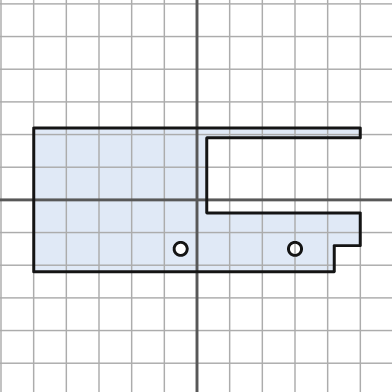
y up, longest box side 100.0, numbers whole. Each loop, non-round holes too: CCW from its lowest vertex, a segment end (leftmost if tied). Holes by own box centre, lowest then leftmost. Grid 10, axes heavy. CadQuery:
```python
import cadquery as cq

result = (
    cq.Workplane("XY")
    .moveTo(-50.0, -22.0)
    .lineTo(42.0, -22.0)
    .lineTo(42.0, -14.0)
    .lineTo(50.0, -14.0)
    .lineTo(50.0, -4.0)
    .lineTo(3.0, -4.0)
    .lineTo(3.0, 19.0)
    .lineTo(50.0, 19.0)
    .lineTo(50.0, 22.0)
    .lineTo(-50.0, 22.0)
    .close()
    .moveTo(-5.0, -15.0)
    .circle(2.0)
    .moveTo(30.0, -15.0)
    .circle(2.0)
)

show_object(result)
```